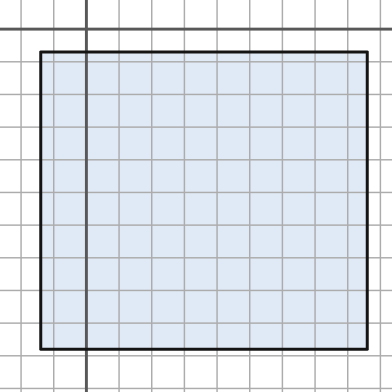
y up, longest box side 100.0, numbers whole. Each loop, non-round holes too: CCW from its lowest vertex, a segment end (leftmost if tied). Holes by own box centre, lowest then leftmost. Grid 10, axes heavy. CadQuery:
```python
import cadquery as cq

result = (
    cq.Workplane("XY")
    .moveTo(-14.0, -98.0)
    .lineTo(86.0, -98.0)
    .lineTo(86.0, -7.0)
    .lineTo(-14.0, -7.0)
    .close()
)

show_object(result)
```